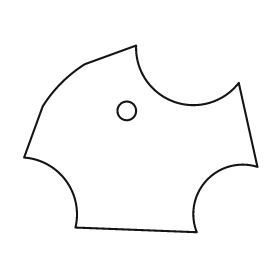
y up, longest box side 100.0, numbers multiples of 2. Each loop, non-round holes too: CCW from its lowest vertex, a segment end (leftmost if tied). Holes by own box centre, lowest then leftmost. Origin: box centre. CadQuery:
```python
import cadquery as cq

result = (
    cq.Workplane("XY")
    .moveTo(24.0, -40.0)
    .threePointArc((28.0, -18.0), (50.0, -12.0))
    .lineTo(42.0, 24.0)
    .threePointArc((14.0, 16.0), (-2.0, 40.0))
    .lineTo(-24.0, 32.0)
    .threePointArc((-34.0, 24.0), (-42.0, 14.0))
    .lineTo(-50.0, -8.0)
    .threePointArc((-32.0, -18.0), (-28.0, -38.0))
    .close()
    .moveTo(-6.0, 12.0)
    .circle(4.0)
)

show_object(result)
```